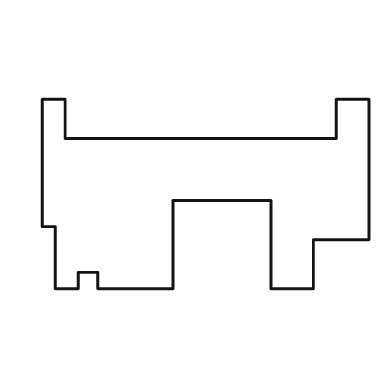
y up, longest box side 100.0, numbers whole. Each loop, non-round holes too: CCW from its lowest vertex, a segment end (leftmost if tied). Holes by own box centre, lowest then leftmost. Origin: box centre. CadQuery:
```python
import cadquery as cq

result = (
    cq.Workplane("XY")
    .moveTo(-46.0, -29.0)
    .lineTo(-39.0, -29.0)
    .lineTo(-39.0, -24.0)
    .lineTo(-33.0, -24.0)
    .lineTo(-33.0, -29.0)
    .lineTo(-10.0, -29.0)
    .lineTo(-10.0, -2.0)
    .lineTo(20.0, -2.0)
    .lineTo(20.0, -29.0)
    .lineTo(33.0, -29.0)
    .lineTo(33.0, -14.0)
    .lineTo(50.0, -14.0)
    .lineTo(50.0, 29.0)
    .lineTo(40.0, 29.0)
    .lineTo(40.0, 17.0)
    .lineTo(-43.0, 17.0)
    .lineTo(-43.0, 29.0)
    .lineTo(-50.0, 29.0)
    .lineTo(-50.0, -10.0)
    .lineTo(-46.0, -10.0)
    .close()
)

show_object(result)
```